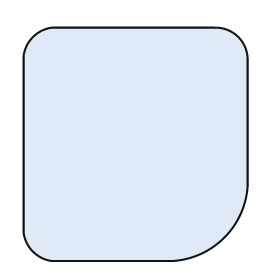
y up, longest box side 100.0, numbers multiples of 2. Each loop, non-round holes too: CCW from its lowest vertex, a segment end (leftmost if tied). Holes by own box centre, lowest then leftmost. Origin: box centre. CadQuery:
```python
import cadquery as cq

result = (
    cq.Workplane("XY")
    .moveTo(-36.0, -50.0)
    .lineTo(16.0, -50.0)
    .threePointArc((38.0, -40.0), (48.0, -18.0))
    .lineTo(48.0, 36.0)
    .threePointArc((44.0, 46.0), (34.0, 50.0))
    .lineTo(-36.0, 50.0)
    .threePointArc((-44.0, 46.0), (-48.0, 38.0))
    .lineTo(-48.0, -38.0)
    .threePointArc((-44.0, -46.0), (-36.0, -50.0))
    .close()
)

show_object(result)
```